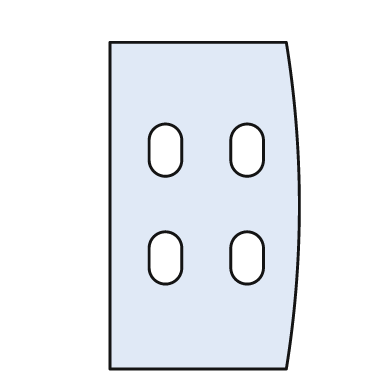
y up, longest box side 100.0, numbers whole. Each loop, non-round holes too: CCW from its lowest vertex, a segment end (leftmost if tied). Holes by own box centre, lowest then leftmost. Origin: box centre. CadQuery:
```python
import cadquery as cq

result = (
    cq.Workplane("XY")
    .moveTo(-29.0, -50.0)
    .lineTo(25.0, -50.0)
    .threePointArc((29.0, 0.0), (25.0, 50.0))
    .lineTo(-29.0, 50.0)
    .close()
    .moveTo(-17.0, -19.0)
    .threePointArc((-12.0, -24.0), (-7.0, -19.0))
    .lineTo(-7.0, -13.0)
    .threePointArc((-12.0, -8.0), (-17.0, -13.0))
    .close()
    .moveTo(8.0, -19.0)
    .threePointArc((13.0, -24.0), (18.0, -19.0))
    .lineTo(18.0, -13.0)
    .threePointArc((13.0, -8.0), (8.0, -13.0))
    .close()
    .moveTo(-17.0, 14.0)
    .threePointArc((-12.0, 9.0), (-7.0, 14.0))
    .lineTo(-7.0, 20.0)
    .threePointArc((-12.0, 25.0), (-17.0, 20.0))
    .close()
    .moveTo(8.0, 14.0)
    .threePointArc((13.0, 9.0), (18.0, 14.0))
    .lineTo(18.0, 20.0)
    .threePointArc((13.0, 25.0), (8.0, 20.0))
    .close()
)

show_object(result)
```